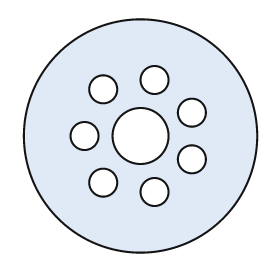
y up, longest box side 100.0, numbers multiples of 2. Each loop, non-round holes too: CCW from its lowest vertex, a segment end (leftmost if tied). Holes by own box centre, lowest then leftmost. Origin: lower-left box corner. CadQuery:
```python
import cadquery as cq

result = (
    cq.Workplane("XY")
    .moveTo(50.0, 50.0)
    .circle(50.0)
    .moveTo(56.0, 26.0)
    .circle(6.0)
    .moveTo(34.0, 30.0)
    .circle(6.0)
    .moveTo(72.0, 40.0)
    .circle(6.0)
    .moveTo(26.0, 50.0)
    .circle(6.0)
    .moveTo(50.0, 50.0)
    .circle(12.0)
    .moveTo(72.0, 60.0)
    .circle(6.0)
    .moveTo(34.0, 70.0)
    .circle(6.0)
    .moveTo(56.0, 74.0)
    .circle(6.0)
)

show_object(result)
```